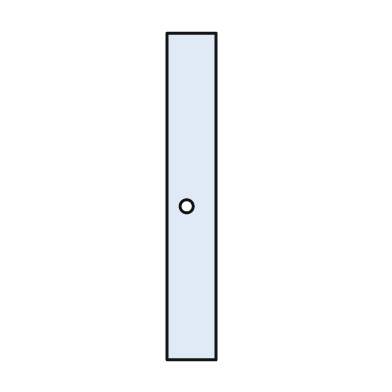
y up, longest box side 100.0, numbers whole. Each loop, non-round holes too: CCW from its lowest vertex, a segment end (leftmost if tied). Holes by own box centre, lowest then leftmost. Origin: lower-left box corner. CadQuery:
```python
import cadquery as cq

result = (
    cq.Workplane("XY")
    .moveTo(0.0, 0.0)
    .lineTo(15.0, 0.0)
    .lineTo(15.0, 100.0)
    .lineTo(0.0, 100.0)
    .close()
    .moveTo(6.0, 47.0)
    .circle(2.0)
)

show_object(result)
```